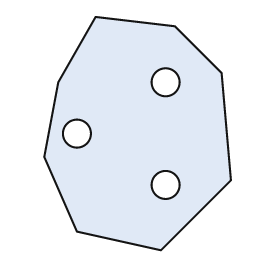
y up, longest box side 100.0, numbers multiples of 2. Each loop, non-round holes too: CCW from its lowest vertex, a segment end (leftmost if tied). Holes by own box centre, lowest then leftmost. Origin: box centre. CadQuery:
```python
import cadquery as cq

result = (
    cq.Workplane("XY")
    .moveTo(10.0, -50.0)
    .lineTo(40.0, -20.0)
    .lineTo(36.0, 26.0)
    .lineTo(16.0, 46.0)
    .lineTo(-18.0, 50.0)
    .lineTo(-34.0, 22.0)
    .lineTo(-40.0, -10.0)
    .lineTo(-26.0, -42.0)
    .close()
    .moveTo(12.0, -22.0)
    .circle(6.0)
    .moveTo(-26.0, 0.0)
    .circle(6.0)
    .moveTo(12.0, 22.0)
    .circle(6.0)
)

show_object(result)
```